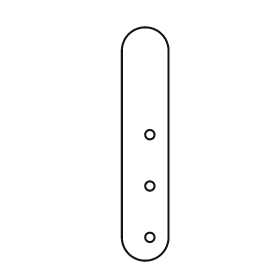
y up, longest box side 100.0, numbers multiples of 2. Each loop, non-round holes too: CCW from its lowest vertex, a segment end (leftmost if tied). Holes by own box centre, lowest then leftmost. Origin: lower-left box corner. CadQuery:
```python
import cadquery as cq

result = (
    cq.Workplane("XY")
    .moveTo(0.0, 10.0)
    .threePointArc((10.0, 0.0), (20.0, 10.0))
    .lineTo(20.0, 90.0)
    .threePointArc((10.0, 100.0), (0.0, 90.0))
    .close()
    .moveTo(12.0, 10.0)
    .circle(2.0)
    .moveTo(12.0, 32.0)
    .circle(2.0)
    .moveTo(12.0, 54.0)
    .circle(2.0)
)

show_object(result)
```